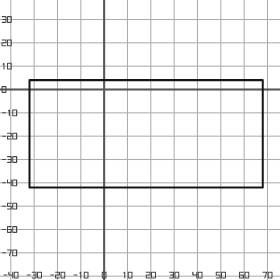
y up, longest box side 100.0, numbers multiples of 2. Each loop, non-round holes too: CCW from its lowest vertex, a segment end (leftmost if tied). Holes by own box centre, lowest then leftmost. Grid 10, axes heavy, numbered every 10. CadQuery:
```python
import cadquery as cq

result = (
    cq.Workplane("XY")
    .moveTo(-32.0, -42.0)
    .lineTo(68.0, -42.0)
    .lineTo(68.0, 4.0)
    .lineTo(-32.0, 4.0)
    .close()
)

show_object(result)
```